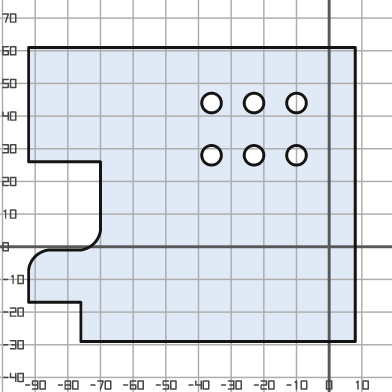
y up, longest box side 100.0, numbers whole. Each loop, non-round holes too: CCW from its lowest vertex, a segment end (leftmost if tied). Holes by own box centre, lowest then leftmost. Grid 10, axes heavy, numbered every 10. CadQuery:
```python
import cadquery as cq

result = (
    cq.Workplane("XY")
    .moveTo(-76.0, -29.0)
    .lineTo(8.0, -29.0)
    .lineTo(8.0, 61.0)
    .lineTo(-92.0, 61.0)
    .lineTo(-92.0, 26.0)
    .lineTo(-70.0, 26.0)
    .lineTo(-70.0, 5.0)
    .threePointArc((-72.0, 1.0), (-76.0, -1.0))
    .lineTo(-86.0, -1.0)
    .threePointArc((-90.0, -3.0), (-92.0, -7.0))
    .lineTo(-92.0, -17.0)
    .lineTo(-76.0, -17.0)
    .close()
    .moveTo(-36.0, 28.0)
    .circle(3.0)
    .moveTo(-23.0, 28.0)
    .circle(3.0)
    .moveTo(-10.0, 28.0)
    .circle(3.0)
    .moveTo(-36.0, 44.0)
    .circle(3.0)
    .moveTo(-23.0, 44.0)
    .circle(3.0)
    .moveTo(-10.0, 44.0)
    .circle(3.0)
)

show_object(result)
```